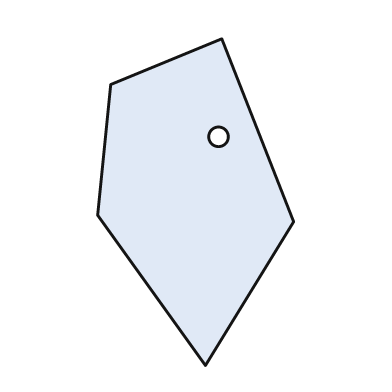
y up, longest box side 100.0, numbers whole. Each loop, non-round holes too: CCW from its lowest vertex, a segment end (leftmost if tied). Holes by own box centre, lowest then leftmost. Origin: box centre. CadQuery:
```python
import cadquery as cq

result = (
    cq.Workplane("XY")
    .moveTo(3.0, -50.0)
    .lineTo(30.0, -6.0)
    .lineTo(8.0, 50.0)
    .lineTo(-26.0, 36.0)
    .lineTo(-30.0, -4.0)
    .close()
    .moveTo(7.0, 20.0)
    .circle(3.0)
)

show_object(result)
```